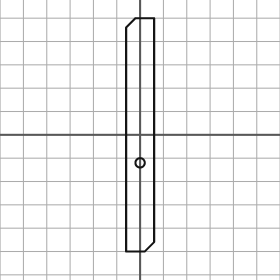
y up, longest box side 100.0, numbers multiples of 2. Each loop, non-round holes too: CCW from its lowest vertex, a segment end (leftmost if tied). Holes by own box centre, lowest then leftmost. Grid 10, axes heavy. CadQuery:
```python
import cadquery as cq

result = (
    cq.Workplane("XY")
    .moveTo(-6.0, -50.0)
    .lineTo(2.0, -50.0)
    .lineTo(6.0, -46.0)
    .lineTo(6.0, 50.0)
    .lineTo(-2.0, 50.0)
    .lineTo(-6.0, 46.0)
    .close()
    .moveTo(0.0, -12.0)
    .circle(2.0)
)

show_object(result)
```